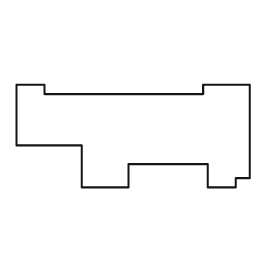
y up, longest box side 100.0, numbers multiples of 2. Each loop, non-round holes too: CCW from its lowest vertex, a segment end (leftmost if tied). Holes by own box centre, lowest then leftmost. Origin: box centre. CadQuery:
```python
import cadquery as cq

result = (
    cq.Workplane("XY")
    .moveTo(-22.0, -22.0)
    .lineTo(-2.0, -22.0)
    .lineTo(-2.0, -12.0)
    .lineTo(32.0, -12.0)
    .lineTo(32.0, -22.0)
    .lineTo(44.0, -22.0)
    .lineTo(44.0, -18.0)
    .lineTo(50.0, -18.0)
    .lineTo(50.0, 22.0)
    .lineTo(30.0, 22.0)
    .lineTo(30.0, 18.0)
    .lineTo(-38.0, 18.0)
    .lineTo(-38.0, 22.0)
    .lineTo(-50.0, 22.0)
    .lineTo(-50.0, -4.0)
    .lineTo(-22.0, -4.0)
    .close()
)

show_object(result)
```